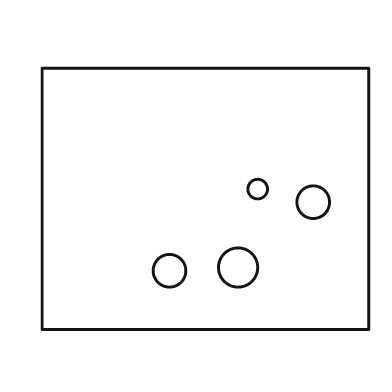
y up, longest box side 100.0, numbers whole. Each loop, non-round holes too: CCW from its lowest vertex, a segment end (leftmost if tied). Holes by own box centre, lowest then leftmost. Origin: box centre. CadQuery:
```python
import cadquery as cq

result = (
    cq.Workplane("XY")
    .moveTo(-50.0, -40.0)
    .lineTo(50.0, -40.0)
    .lineTo(50.0, 40.0)
    .lineTo(-50.0, 40.0)
    .close()
    .moveTo(-11.0, -22.0)
    .circle(5.0)
    .moveTo(10.0, -21.0)
    .circle(6.0)
    .moveTo(33.0, -1.0)
    .circle(5.0)
    .moveTo(16.0, 3.0)
    .circle(3.0)
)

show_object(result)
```